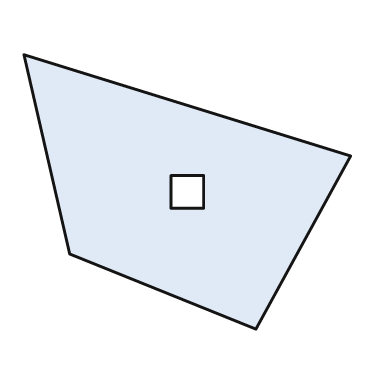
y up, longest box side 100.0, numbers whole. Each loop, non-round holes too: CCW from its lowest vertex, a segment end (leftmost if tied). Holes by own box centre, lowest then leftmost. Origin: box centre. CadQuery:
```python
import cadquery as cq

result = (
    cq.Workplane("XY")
    .moveTo(21.0, -42.0)
    .lineTo(50.0, 11.0)
    .lineTo(-50.0, 42.0)
    .lineTo(-36.0, -19.0)
    .close()
    .moveTo(-5.0, -5.0)
    .lineTo(5.0, -5.0)
    .lineTo(5.0, 5.0)
    .lineTo(-5.0, 5.0)
    .close()
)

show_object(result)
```